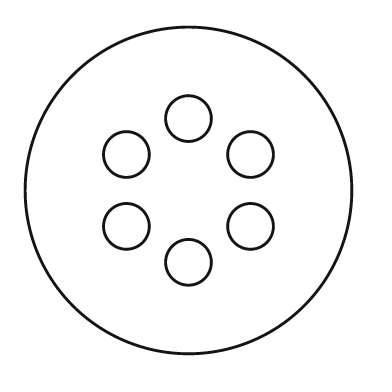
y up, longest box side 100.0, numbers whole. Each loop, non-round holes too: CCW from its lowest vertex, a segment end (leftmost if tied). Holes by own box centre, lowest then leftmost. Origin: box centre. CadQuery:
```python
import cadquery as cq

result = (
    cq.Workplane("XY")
    .moveTo(0.0, 0.0)
    .circle(50.0)
    .moveTo(0.0, -22.0)
    .circle(7.0)
    .moveTo(-19.0, -11.0)
    .circle(7.0)
    .moveTo(19.0, -11.0)
    .circle(7.0)
    .moveTo(-19.0, 11.0)
    .circle(7.0)
    .moveTo(19.0, 11.0)
    .circle(7.0)
    .moveTo(0.0, 22.0)
    .circle(7.0)
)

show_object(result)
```